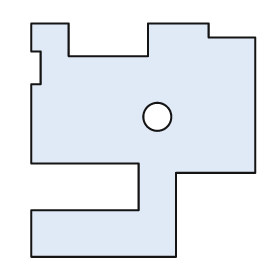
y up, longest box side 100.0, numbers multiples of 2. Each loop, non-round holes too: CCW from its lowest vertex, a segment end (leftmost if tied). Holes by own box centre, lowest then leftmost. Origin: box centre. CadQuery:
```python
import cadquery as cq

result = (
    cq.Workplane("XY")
    .moveTo(-48.0, -50.0)
    .lineTo(14.0, -50.0)
    .lineTo(14.0, -14.0)
    .lineTo(48.0, -14.0)
    .lineTo(48.0, 44.0)
    .lineTo(28.0, 44.0)
    .lineTo(28.0, 50.0)
    .lineTo(2.0, 50.0)
    .lineTo(2.0, 36.0)
    .lineTo(-32.0, 36.0)
    .lineTo(-32.0, 50.0)
    .lineTo(-48.0, 50.0)
    .lineTo(-48.0, 38.0)
    .lineTo(-44.0, 38.0)
    .lineTo(-44.0, 24.0)
    .lineTo(-48.0, 24.0)
    .lineTo(-48.0, -10.0)
    .lineTo(-2.0, -10.0)
    .lineTo(-2.0, -30.0)
    .lineTo(-48.0, -30.0)
    .close()
    .moveTo(6.0, 10.0)
    .circle(6.0)
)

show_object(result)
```